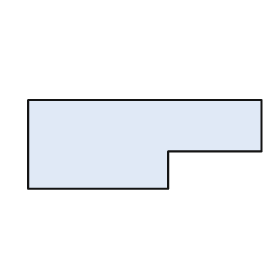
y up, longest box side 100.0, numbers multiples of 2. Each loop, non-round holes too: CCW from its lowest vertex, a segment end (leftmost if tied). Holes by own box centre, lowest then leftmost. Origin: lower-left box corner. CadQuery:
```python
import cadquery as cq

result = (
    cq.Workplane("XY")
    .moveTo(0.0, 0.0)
    .lineTo(60.0, 0.0)
    .lineTo(60.0, 16.0)
    .lineTo(100.0, 16.0)
    .lineTo(100.0, 38.0)
    .lineTo(0.0, 38.0)
    .close()
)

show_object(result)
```